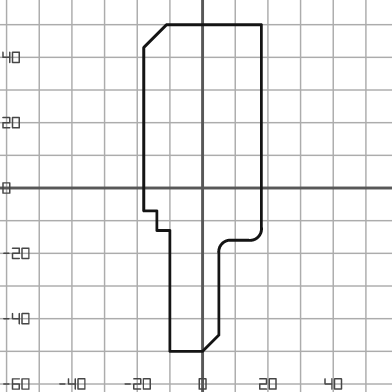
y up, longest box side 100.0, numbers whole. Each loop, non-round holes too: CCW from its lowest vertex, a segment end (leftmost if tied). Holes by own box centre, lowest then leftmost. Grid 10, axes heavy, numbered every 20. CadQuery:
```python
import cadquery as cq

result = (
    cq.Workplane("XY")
    .moveTo(-10.0, -50.0)
    .lineTo(0.0, -50.0)
    .lineTo(5.0, -45.0)
    .lineTo(5.0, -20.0)
    .threePointArc((6.0, -17.0), (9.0, -16.0))
    .lineTo(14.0, -16.0)
    .threePointArc((17.0, -15.0), (18.0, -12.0))
    .lineTo(18.0, 50.0)
    .lineTo(-11.0, 50.0)
    .lineTo(-18.0, 43.0)
    .lineTo(-18.0, -7.0)
    .lineTo(-14.0, -7.0)
    .lineTo(-14.0, -13.0)
    .lineTo(-10.0, -13.0)
    .close()
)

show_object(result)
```